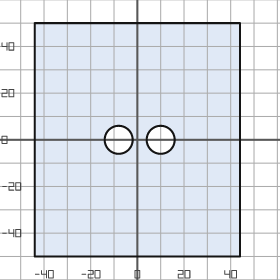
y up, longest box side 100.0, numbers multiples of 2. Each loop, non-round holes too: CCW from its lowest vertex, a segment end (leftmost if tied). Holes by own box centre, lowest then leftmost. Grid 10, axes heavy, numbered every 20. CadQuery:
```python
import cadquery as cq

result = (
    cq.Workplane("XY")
    .moveTo(-44.0, -50.0)
    .lineTo(44.0, -50.0)
    .lineTo(44.0, 50.0)
    .lineTo(-44.0, 50.0)
    .close()
    .moveTo(-8.0, 0.0)
    .circle(6.0)
    .moveTo(10.0, 0.0)
    .circle(6.0)
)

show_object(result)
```